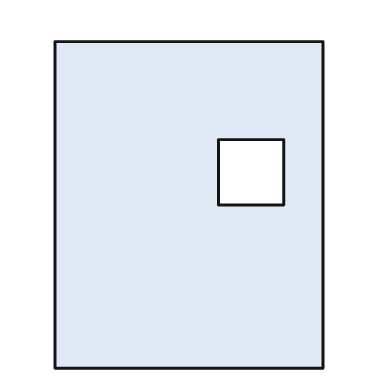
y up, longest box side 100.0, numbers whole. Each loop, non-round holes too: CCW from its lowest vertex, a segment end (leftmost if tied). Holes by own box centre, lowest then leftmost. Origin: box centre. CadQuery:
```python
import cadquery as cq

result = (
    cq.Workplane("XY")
    .moveTo(-41.0, -50.0)
    .lineTo(41.0, -50.0)
    .lineTo(41.0, 50.0)
    .lineTo(-41.0, 50.0)
    .close()
    .moveTo(9.0, 0.0)
    .lineTo(29.0, 0.0)
    .lineTo(29.0, 20.0)
    .lineTo(9.0, 20.0)
    .close()
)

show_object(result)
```